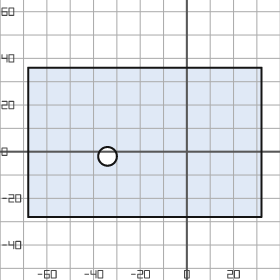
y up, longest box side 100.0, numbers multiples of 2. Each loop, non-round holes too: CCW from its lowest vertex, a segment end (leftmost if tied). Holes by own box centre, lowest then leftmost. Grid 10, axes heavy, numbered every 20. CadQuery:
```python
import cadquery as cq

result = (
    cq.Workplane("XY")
    .moveTo(-68.0, -28.0)
    .lineTo(32.0, -28.0)
    .lineTo(32.0, 36.0)
    .lineTo(-68.0, 36.0)
    .close()
    .moveTo(-34.0, -2.0)
    .circle(4.0)
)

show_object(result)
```